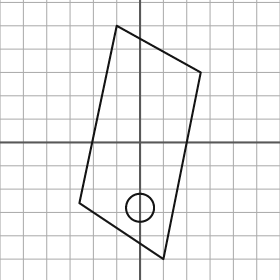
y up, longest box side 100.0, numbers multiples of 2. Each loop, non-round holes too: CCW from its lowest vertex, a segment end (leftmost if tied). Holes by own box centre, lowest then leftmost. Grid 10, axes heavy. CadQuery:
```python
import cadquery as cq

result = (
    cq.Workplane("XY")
    .moveTo(10.0, -50.0)
    .lineTo(26.0, 30.0)
    .lineTo(-10.0, 50.0)
    .lineTo(-26.0, -26.0)
    .close()
    .moveTo(0.0, -28.0)
    .circle(6.0)
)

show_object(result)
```